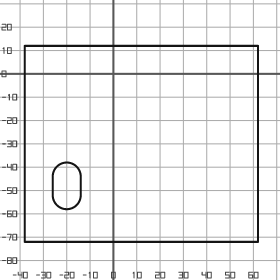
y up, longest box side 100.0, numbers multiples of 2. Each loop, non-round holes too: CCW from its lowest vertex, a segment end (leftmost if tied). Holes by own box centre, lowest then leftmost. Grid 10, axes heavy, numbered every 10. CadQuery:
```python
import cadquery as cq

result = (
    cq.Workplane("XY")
    .moveTo(-38.0, -72.0)
    .lineTo(62.0, -72.0)
    .lineTo(62.0, 12.0)
    .lineTo(-38.0, 12.0)
    .close()
    .moveTo(-26.0, -52.0)
    .threePointArc((-20.0, -58.0), (-14.0, -52.0))
    .lineTo(-14.0, -44.0)
    .threePointArc((-20.0, -38.0), (-26.0, -44.0))
    .close()
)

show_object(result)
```